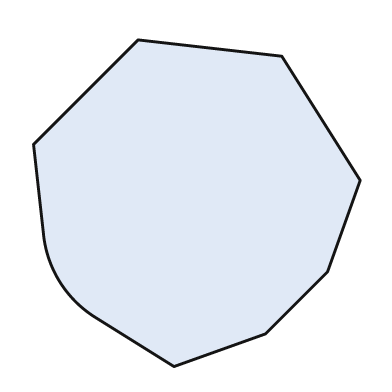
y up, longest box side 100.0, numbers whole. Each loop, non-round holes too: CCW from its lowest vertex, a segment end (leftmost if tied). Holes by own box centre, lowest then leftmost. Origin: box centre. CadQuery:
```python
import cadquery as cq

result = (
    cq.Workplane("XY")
    .moveTo(-7.0, -50.0)
    .lineTo(21.0, -40.0)
    .lineTo(40.0, -21.0)
    .lineTo(50.0, 7.0)
    .lineTo(26.0, 45.0)
    .lineTo(-18.0, 50.0)
    .lineTo(-50.0, 18.0)
    .lineTo(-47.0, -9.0)
    .threePointArc((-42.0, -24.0), (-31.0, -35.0))
    .close()
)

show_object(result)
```